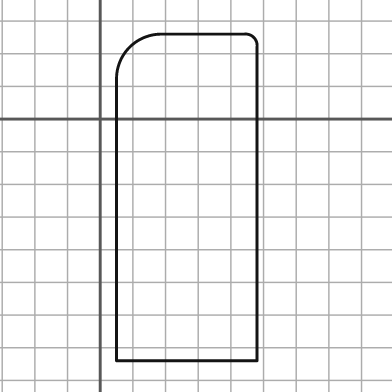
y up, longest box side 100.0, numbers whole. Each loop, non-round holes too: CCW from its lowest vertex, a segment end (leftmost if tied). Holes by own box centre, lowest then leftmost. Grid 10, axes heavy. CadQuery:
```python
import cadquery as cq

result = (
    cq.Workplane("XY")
    .moveTo(5.0, -74.0)
    .lineTo(48.0, -74.0)
    .lineTo(48.0, 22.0)
    .threePointArc((47.0, 25.0), (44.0, 26.0))
    .lineTo(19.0, 26.0)
    .threePointArc((9.0, 22.0), (5.0, 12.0))
    .close()
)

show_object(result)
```